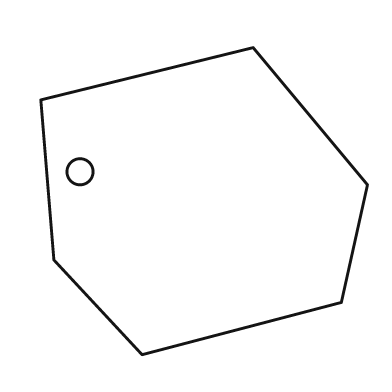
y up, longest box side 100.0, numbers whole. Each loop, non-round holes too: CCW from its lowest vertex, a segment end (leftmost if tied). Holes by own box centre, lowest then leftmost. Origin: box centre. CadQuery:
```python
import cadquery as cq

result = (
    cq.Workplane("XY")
    .moveTo(-19.0, -47.0)
    .lineTo(42.0, -31.0)
    .lineTo(50.0, 5.0)
    .lineTo(15.0, 47.0)
    .lineTo(-50.0, 31.0)
    .lineTo(-46.0, -18.0)
    .close()
    .moveTo(-38.0, 9.0)
    .circle(4.0)
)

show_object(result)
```